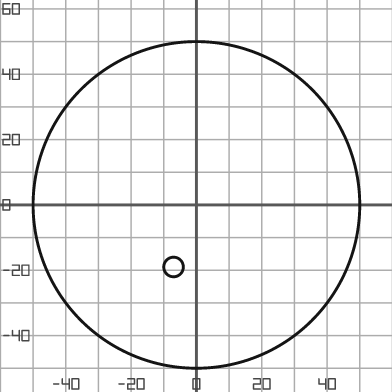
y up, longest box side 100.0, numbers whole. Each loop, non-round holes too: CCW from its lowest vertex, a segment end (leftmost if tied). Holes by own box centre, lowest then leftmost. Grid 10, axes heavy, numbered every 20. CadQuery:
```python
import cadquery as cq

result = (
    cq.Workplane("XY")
    .moveTo(0.0, 0.0)
    .circle(50.0)
    .moveTo(-7.0, -19.0)
    .circle(3.0)
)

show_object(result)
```